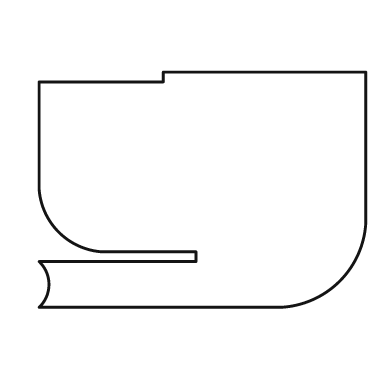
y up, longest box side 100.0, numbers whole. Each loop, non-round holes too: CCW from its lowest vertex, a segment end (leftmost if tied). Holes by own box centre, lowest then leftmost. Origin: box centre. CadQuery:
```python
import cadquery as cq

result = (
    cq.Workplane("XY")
    .moveTo(-50.0, -36.0)
    .lineTo(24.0, -36.0)
    .threePointArc((42.0, -28.0), (50.0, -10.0))
    .lineTo(50.0, 36.0)
    .lineTo(-12.0, 36.0)
    .lineTo(-12.0, 33.0)
    .lineTo(-50.0, 33.0)
    .lineTo(-50.0, 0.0)
    .threePointArc((-44.0, -13.0), (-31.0, -19.0))
    .lineTo(-2.0, -19.0)
    .lineTo(-2.0, -22.0)
    .lineTo(-50.0, -22.0)
    .threePointArc((-47.0, -29.0), (-50.0, -36.0))
    .close()
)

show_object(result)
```